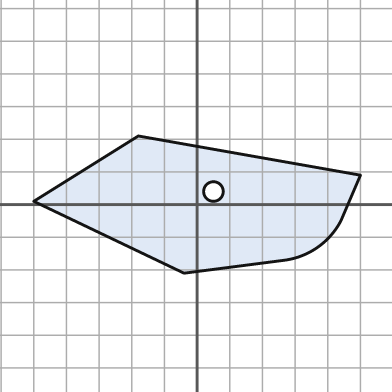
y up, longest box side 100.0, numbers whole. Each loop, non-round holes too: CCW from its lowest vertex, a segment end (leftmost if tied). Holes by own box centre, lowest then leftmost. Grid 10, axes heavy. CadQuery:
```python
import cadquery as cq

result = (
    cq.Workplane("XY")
    .moveTo(-4.0, -21.0)
    .lineTo(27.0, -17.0)
    .threePointArc((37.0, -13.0), (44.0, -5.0))
    .lineTo(50.0, 9.0)
    .lineTo(-18.0, 21.0)
    .lineTo(-50.0, 1.0)
    .close()
    .moveTo(5.0, 4.0)
    .circle(3.0)
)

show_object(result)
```